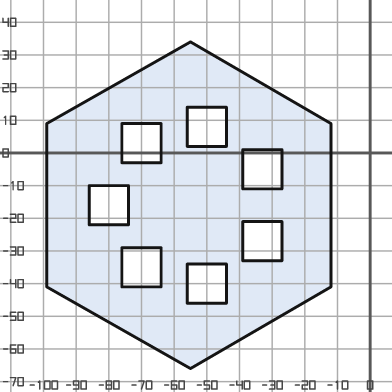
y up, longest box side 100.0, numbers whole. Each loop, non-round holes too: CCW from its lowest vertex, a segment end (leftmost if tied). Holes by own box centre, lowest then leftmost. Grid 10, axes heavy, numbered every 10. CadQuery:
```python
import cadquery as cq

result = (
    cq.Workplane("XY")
    .moveTo(-55.0, -66.0)
    .lineTo(-12.0, -41.0)
    .lineTo(-12.0, 9.0)
    .lineTo(-55.0, 34.0)
    .lineTo(-99.0, 9.0)
    .lineTo(-99.0, -41.0)
    .close()
    .moveTo(-56.0, -46.0)
    .lineTo(-44.0, -46.0)
    .lineTo(-44.0, -34.0)
    .lineTo(-56.0, -34.0)
    .close()
    .moveTo(-76.0, -41.0)
    .lineTo(-64.0, -41.0)
    .lineTo(-64.0, -29.0)
    .lineTo(-76.0, -29.0)
    .close()
    .moveTo(-39.0, -33.0)
    .lineTo(-27.0, -33.0)
    .lineTo(-27.0, -21.0)
    .lineTo(-39.0, -21.0)
    .close()
    .moveTo(-86.0, -22.0)
    .lineTo(-74.0, -22.0)
    .lineTo(-74.0, -10.0)
    .lineTo(-86.0, -10.0)
    .close()
    .moveTo(-39.0, -11.0)
    .lineTo(-27.0, -11.0)
    .lineTo(-27.0, 1.0)
    .lineTo(-39.0, 1.0)
    .close()
    .moveTo(-76.0, -3.0)
    .lineTo(-64.0, -3.0)
    .lineTo(-64.0, 9.0)
    .lineTo(-76.0, 9.0)
    .close()
    .moveTo(-56.0, 2.0)
    .lineTo(-44.0, 2.0)
    .lineTo(-44.0, 14.0)
    .lineTo(-56.0, 14.0)
    .close()
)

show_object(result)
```